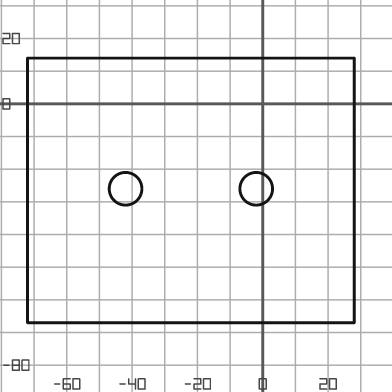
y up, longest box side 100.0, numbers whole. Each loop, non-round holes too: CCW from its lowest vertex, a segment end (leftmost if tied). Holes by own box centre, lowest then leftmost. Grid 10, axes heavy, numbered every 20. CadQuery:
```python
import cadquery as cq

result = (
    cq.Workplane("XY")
    .moveTo(-72.0, -67.0)
    .lineTo(28.0, -67.0)
    .lineTo(28.0, 14.0)
    .lineTo(-72.0, 14.0)
    .close()
    .moveTo(-42.0, -26.0)
    .circle(5.0)
    .moveTo(-2.0, -26.0)
    .circle(5.0)
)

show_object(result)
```